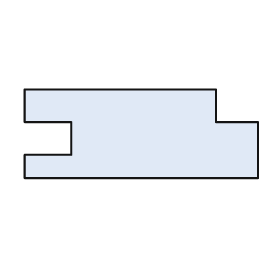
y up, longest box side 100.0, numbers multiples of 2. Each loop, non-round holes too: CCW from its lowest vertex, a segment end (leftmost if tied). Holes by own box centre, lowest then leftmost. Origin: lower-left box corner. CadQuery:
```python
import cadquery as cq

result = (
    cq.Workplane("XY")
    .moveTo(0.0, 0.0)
    .lineTo(100.0, 0.0)
    .lineTo(100.0, 24.0)
    .lineTo(82.0, 24.0)
    .lineTo(82.0, 38.0)
    .lineTo(0.0, 38.0)
    .lineTo(0.0, 24.0)
    .lineTo(20.0, 24.0)
    .lineTo(20.0, 10.0)
    .lineTo(0.0, 10.0)
    .close()
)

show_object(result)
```